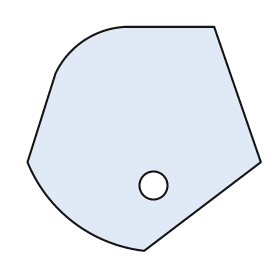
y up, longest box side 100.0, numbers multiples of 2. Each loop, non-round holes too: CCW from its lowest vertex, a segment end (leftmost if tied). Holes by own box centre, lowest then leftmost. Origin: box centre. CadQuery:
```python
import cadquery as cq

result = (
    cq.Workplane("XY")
    .moveTo(0.0, -48.0)
    .lineTo(50.0, -10.0)
    .lineTo(30.0, 48.0)
    .lineTo(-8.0, 48.0)
    .threePointArc((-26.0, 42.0), (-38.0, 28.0))
    .lineTo(-50.0, -10.0)
    .threePointArc((-30.0, -36.0), (0.0, -48.0))
    .close()
    .moveTo(4.0, -20.0)
    .circle(6.0)
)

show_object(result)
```